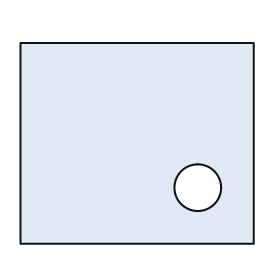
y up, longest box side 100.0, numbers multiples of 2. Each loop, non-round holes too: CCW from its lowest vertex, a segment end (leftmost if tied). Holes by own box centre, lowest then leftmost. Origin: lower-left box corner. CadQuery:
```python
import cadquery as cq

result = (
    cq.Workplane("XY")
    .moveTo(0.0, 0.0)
    .lineTo(100.0, 0.0)
    .lineTo(100.0, 86.0)
    .lineTo(0.0, 86.0)
    .close()
    .moveTo(76.0, 24.0)
    .circle(10.0)
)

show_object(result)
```